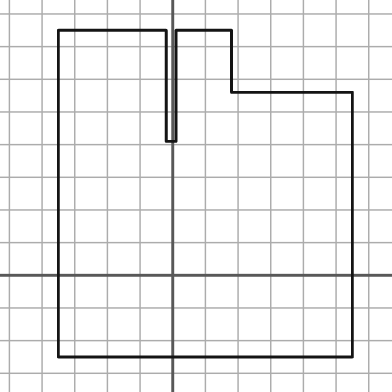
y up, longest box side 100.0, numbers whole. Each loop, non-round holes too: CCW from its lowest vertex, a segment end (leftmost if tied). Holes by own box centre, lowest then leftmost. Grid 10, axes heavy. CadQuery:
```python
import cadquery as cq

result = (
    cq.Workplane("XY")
    .moveTo(-35.0, -25.0)
    .lineTo(55.0, -25.0)
    .lineTo(55.0, 56.0)
    .lineTo(18.0, 56.0)
    .lineTo(18.0, 75.0)
    .lineTo(1.0, 75.0)
    .lineTo(1.0, 41.0)
    .lineTo(-2.0, 41.0)
    .lineTo(-2.0, 75.0)
    .lineTo(-35.0, 75.0)
    .close()
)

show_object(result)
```